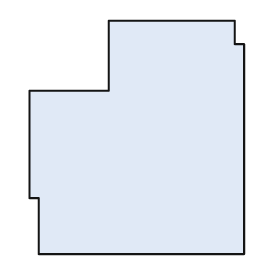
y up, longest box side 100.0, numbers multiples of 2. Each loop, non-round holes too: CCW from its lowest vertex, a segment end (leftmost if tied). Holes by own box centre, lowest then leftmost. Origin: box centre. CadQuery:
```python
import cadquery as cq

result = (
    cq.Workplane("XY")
    .moveTo(-42.0, -50.0)
    .lineTo(46.0, -50.0)
    .lineTo(46.0, 40.0)
    .lineTo(42.0, 40.0)
    .lineTo(42.0, 50.0)
    .lineTo(-12.0, 50.0)
    .lineTo(-12.0, 20.0)
    .lineTo(-46.0, 20.0)
    .lineTo(-46.0, -26.0)
    .lineTo(-42.0, -26.0)
    .close()
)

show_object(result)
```